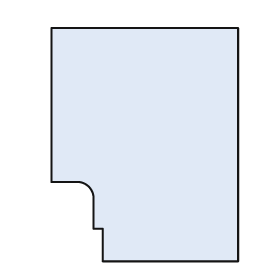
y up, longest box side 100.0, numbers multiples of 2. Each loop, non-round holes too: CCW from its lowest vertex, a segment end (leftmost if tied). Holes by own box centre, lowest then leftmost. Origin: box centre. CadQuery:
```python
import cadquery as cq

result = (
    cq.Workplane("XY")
    .moveTo(-18.0, -50.0)
    .lineTo(40.0, -50.0)
    .lineTo(40.0, 50.0)
    .lineTo(-40.0, 50.0)
    .lineTo(-40.0, -16.0)
    .lineTo(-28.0, -16.0)
    .threePointArc((-24.0, -18.0), (-22.0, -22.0))
    .lineTo(-22.0, -36.0)
    .lineTo(-18.0, -36.0)
    .close()
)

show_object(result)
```